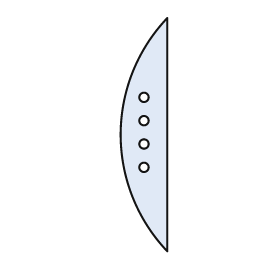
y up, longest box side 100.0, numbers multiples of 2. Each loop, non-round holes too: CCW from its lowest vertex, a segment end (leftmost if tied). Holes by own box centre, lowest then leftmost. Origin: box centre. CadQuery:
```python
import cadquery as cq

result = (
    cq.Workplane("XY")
    .moveTo(10.0, -50.0)
    .lineTo(10.0, 50.0)
    .threePointArc((-10.0, 0.0), (10.0, -50.0))
    .close()
    .moveTo(0.0, -14.0)
    .circle(2.0)
    .moveTo(0.0, -4.0)
    .circle(2.0)
    .moveTo(0.0, 6.0)
    .circle(2.0)
    .moveTo(0.0, 16.0)
    .circle(2.0)
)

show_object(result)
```